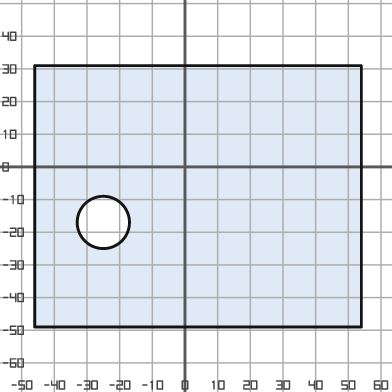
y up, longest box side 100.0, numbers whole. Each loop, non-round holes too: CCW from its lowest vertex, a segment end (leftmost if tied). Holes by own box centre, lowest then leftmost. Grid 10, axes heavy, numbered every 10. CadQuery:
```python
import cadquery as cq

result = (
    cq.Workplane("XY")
    .moveTo(-46.0, -49.0)
    .lineTo(54.0, -49.0)
    .lineTo(54.0, 31.0)
    .lineTo(-46.0, 31.0)
    .close()
    .moveTo(-25.0, -17.0)
    .circle(8.0)
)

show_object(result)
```